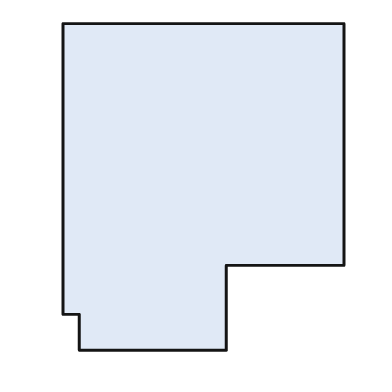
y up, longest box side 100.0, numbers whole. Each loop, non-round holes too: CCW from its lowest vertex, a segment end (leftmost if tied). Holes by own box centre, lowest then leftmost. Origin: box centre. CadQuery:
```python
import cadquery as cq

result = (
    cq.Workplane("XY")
    .moveTo(-38.0, -50.0)
    .lineTo(7.0, -50.0)
    .lineTo(7.0, -24.0)
    .lineTo(43.0, -24.0)
    .lineTo(43.0, 50.0)
    .lineTo(-43.0, 50.0)
    .lineTo(-43.0, -39.0)
    .lineTo(-38.0, -39.0)
    .close()
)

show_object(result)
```